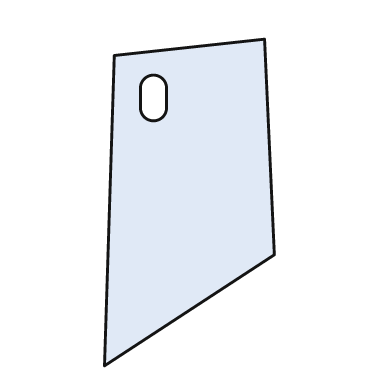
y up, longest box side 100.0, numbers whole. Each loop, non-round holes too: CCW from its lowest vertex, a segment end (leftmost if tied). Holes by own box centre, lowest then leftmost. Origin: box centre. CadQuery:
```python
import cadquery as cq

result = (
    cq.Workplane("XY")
    .moveTo(-26.0, -50.0)
    .lineTo(26.0, -16.0)
    .lineTo(23.0, 50.0)
    .lineTo(-23.0, 45.0)
    .close()
    .moveTo(-15.0, 29.0)
    .threePointArc((-11.0, 25.0), (-7.0, 29.0))
    .lineTo(-7.0, 35.0)
    .threePointArc((-11.0, 39.0), (-15.0, 35.0))
    .close()
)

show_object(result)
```